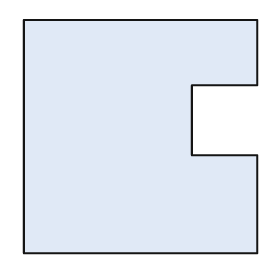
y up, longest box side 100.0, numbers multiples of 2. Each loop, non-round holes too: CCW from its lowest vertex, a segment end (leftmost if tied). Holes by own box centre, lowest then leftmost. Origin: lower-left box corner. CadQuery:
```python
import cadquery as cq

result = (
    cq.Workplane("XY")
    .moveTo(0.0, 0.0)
    .lineTo(100.0, 0.0)
    .lineTo(100.0, 42.0)
    .lineTo(72.0, 42.0)
    .lineTo(72.0, 72.0)
    .lineTo(100.0, 72.0)
    .lineTo(100.0, 100.0)
    .lineTo(0.0, 100.0)
    .close()
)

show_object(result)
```